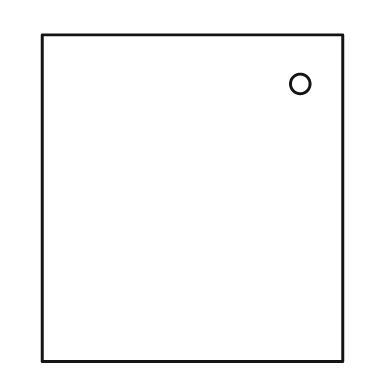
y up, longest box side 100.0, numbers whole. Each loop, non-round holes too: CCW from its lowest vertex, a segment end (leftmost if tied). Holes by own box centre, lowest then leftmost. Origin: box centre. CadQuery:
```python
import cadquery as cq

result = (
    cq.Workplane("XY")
    .moveTo(-46.0, -50.0)
    .lineTo(46.0, -50.0)
    .lineTo(46.0, 50.0)
    .lineTo(-46.0, 50.0)
    .close()
    .moveTo(33.0, 35.0)
    .circle(3.0)
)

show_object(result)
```